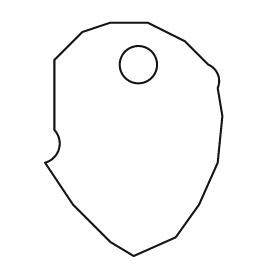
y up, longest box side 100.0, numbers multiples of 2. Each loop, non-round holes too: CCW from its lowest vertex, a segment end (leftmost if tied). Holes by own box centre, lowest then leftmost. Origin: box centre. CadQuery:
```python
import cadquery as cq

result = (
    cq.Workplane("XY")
    .moveTo(0.0, -50.0)
    .lineTo(18.0, -42.0)
    .lineTo(28.0, -28.0)
    .lineTo(36.0, -10.0)
    .lineTo(38.0, 10.0)
    .lineTo(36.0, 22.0)
    .threePointArc((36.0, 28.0), (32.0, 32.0))
    .lineTo(22.0, 42.0)
    .lineTo(6.0, 50.0)
    .lineTo(-10.0, 50.0)
    .lineTo(-22.0, 46.0)
    .lineTo(-34.0, 34.0)
    .lineTo(-34.0, 4.0)
    .threePointArc((-32.0, -4.0), (-38.0, -10.0))
    .lineTo(-26.0, -28.0)
    .lineTo(-10.0, -44.0)
    .close()
    .moveTo(2.0, 32.0)
    .circle(8.0)
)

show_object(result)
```